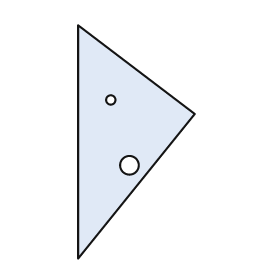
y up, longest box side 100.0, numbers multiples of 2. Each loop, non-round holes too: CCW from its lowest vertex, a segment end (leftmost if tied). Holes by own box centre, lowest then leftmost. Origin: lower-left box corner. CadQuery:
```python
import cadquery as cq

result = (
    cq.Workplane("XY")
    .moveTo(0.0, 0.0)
    .lineTo(50.0, 62.0)
    .lineTo(0.0, 100.0)
    .close()
    .moveTo(22.0, 40.0)
    .circle(4.0)
    .moveTo(14.0, 68.0)
    .circle(2.0)
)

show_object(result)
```